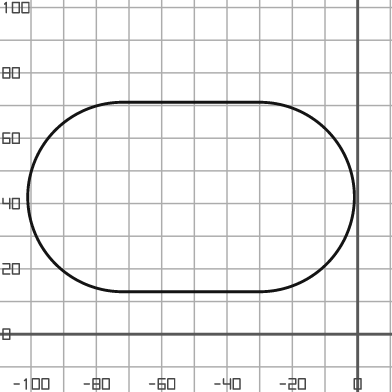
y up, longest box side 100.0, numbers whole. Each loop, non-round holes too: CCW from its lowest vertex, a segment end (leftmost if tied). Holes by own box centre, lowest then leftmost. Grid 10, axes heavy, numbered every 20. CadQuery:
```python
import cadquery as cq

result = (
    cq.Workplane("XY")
    .moveTo(-72.0, 13.0)
    .lineTo(-30.0, 13.0)
    .threePointArc((-1.0, 42.0), (-30.0, 71.0))
    .lineTo(-72.0, 71.0)
    .threePointArc((-101.0, 42.0), (-72.0, 13.0))
    .close()
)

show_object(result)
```